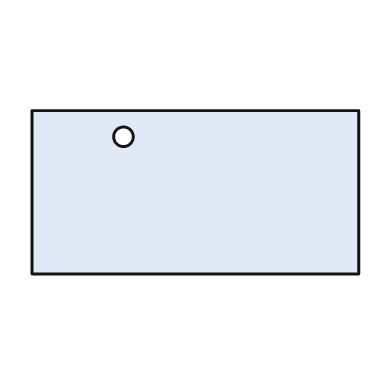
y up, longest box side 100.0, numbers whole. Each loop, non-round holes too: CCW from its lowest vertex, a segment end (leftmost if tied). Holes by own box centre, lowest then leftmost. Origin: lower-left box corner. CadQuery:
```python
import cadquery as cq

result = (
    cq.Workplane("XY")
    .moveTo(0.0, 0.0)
    .lineTo(100.0, 0.0)
    .lineTo(100.0, 50.0)
    .lineTo(0.0, 50.0)
    .close()
    .moveTo(28.0, 42.0)
    .circle(3.0)
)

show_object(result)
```